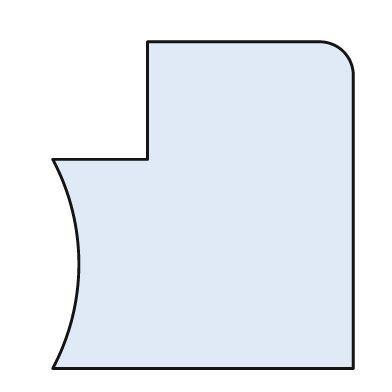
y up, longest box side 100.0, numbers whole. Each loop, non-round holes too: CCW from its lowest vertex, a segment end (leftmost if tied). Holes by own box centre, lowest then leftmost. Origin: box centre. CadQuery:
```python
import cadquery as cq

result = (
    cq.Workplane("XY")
    .moveTo(-46.0, -50.0)
    .lineTo(46.0, -50.0)
    .lineTo(46.0, 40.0)
    .threePointArc((43.0, 47.0), (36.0, 50.0))
    .lineTo(-17.0, 50.0)
    .lineTo(-17.0, 14.0)
    .lineTo(-46.0, 14.0)
    .threePointArc((-38.0, -18.0), (-46.0, -50.0))
    .close()
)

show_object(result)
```